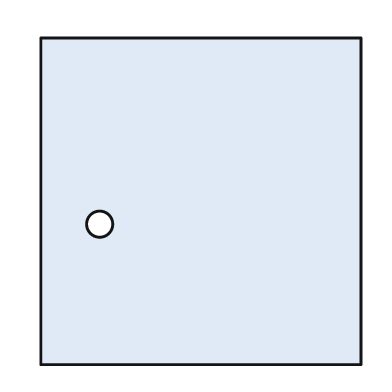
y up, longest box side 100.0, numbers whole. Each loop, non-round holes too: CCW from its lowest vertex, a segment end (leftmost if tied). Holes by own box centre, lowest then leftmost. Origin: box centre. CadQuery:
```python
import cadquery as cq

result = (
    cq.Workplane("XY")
    .moveTo(-49.0, -50.0)
    .lineTo(49.0, -50.0)
    .lineTo(49.0, 50.0)
    .lineTo(-49.0, 50.0)
    .close()
    .moveTo(-31.0, -7.0)
    .circle(4.0)
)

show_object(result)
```